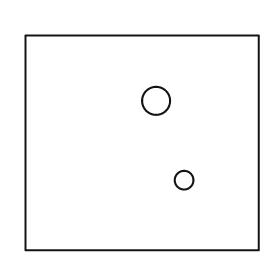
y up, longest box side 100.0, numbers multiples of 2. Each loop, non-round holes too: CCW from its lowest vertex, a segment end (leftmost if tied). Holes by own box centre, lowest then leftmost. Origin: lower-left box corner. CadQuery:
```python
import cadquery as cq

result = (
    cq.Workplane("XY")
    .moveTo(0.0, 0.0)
    .lineTo(100.0, 0.0)
    .lineTo(100.0, 92.0)
    .lineTo(0.0, 92.0)
    .close()
    .moveTo(68.0, 30.0)
    .circle(4.0)
    .moveTo(56.0, 64.0)
    .circle(6.0)
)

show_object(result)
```